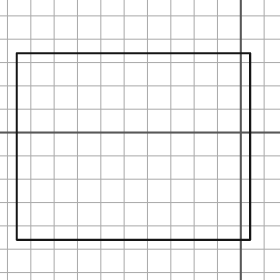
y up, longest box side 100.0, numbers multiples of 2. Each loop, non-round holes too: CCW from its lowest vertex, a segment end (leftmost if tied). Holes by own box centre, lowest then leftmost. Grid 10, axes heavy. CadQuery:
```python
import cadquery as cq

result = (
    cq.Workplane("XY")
    .moveTo(-96.0, -46.0)
    .lineTo(4.0, -46.0)
    .lineTo(4.0, 34.0)
    .lineTo(-96.0, 34.0)
    .close()
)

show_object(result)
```